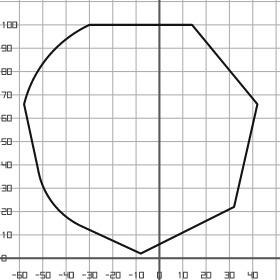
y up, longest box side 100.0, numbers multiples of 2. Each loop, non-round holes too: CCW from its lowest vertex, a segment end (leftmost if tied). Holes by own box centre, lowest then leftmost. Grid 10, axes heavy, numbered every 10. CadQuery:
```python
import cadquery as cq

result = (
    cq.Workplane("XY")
    .moveTo(-8.0, 2.0)
    .lineTo(32.0, 22.0)
    .lineTo(42.0, 66.0)
    .lineTo(14.0, 100.0)
    .lineTo(-30.0, 100.0)
    .threePointArc((-48.0, 86.0), (-58.0, 66.0))
    .lineTo(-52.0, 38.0)
    .threePointArc((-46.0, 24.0), (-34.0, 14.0))
    .close()
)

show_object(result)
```